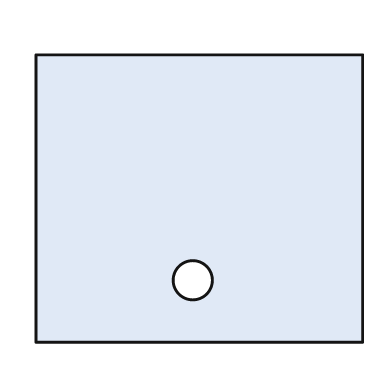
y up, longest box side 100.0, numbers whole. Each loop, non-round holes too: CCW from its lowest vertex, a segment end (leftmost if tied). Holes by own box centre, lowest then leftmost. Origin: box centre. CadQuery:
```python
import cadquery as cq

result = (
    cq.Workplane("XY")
    .moveTo(-50.0, -44.0)
    .lineTo(50.0, -44.0)
    .lineTo(50.0, 44.0)
    .lineTo(-50.0, 44.0)
    .close()
    .moveTo(-2.0, -25.0)
    .circle(6.0)
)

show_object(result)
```